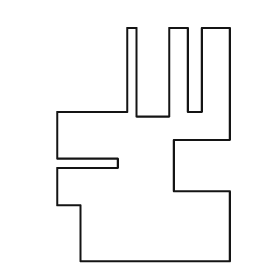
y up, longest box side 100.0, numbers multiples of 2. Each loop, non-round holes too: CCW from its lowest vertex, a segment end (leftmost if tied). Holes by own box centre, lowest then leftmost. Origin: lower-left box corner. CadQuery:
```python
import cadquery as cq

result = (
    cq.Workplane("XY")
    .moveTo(10.0, 0.0)
    .lineTo(74.0, 0.0)
    .lineTo(74.0, 30.0)
    .lineTo(50.0, 30.0)
    .lineTo(50.0, 52.0)
    .lineTo(74.0, 52.0)
    .lineTo(74.0, 100.0)
    .lineTo(62.0, 100.0)
    .lineTo(62.0, 64.0)
    .lineTo(56.0, 64.0)
    .lineTo(56.0, 100.0)
    .lineTo(48.0, 100.0)
    .lineTo(48.0, 62.0)
    .lineTo(34.0, 62.0)
    .lineTo(34.0, 100.0)
    .lineTo(30.0, 100.0)
    .lineTo(30.0, 64.0)
    .lineTo(0.0, 64.0)
    .lineTo(0.0, 44.0)
    .lineTo(26.0, 44.0)
    .lineTo(26.0, 40.0)
    .lineTo(0.0, 40.0)
    .lineTo(0.0, 24.0)
    .lineTo(10.0, 24.0)
    .close()
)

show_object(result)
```